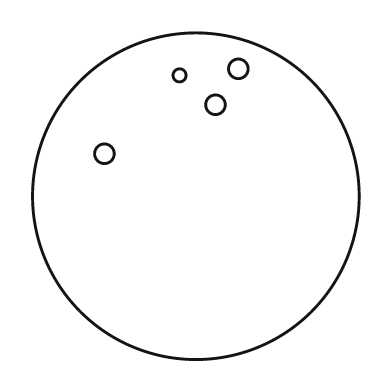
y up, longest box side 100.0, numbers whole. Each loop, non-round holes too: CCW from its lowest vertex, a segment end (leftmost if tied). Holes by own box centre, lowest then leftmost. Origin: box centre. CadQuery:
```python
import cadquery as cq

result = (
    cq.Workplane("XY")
    .moveTo(0.0, 0.0)
    .circle(50.0)
    .moveTo(-28.0, 13.0)
    .circle(3.0)
    .moveTo(6.0, 28.0)
    .circle(3.0)
    .moveTo(-5.0, 37.0)
    .circle(2.0)
    .moveTo(13.0, 39.0)
    .circle(3.0)
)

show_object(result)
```